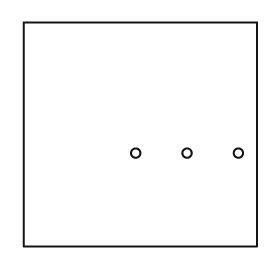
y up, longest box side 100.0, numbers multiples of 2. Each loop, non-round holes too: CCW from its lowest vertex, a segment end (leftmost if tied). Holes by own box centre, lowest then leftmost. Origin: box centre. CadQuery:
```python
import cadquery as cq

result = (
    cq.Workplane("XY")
    .moveTo(-50.0, -48.0)
    .lineTo(50.0, -48.0)
    .lineTo(50.0, 48.0)
    .lineTo(-50.0, 48.0)
    .close()
    .moveTo(-2.0, -8.0)
    .circle(2.0)
    .moveTo(20.0, -8.0)
    .circle(2.0)
    .moveTo(42.0, -8.0)
    .circle(2.0)
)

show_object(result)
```